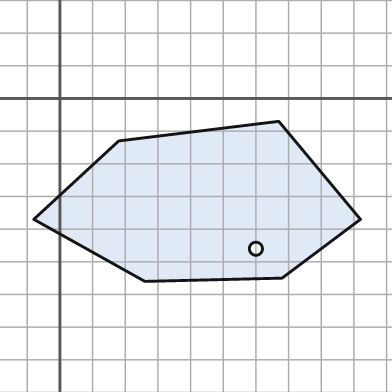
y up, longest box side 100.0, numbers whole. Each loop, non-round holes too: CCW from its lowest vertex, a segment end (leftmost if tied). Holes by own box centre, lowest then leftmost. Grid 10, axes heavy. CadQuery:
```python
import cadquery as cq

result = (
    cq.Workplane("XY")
    .moveTo(26.0, -56.0)
    .lineTo(68.0, -55.0)
    .lineTo(92.0, -37.0)
    .lineTo(67.0, -7.0)
    .lineTo(18.0, -13.0)
    .lineTo(-8.0, -37.0)
    .close()
    .moveTo(60.0, -46.0)
    .circle(2.0)
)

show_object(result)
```